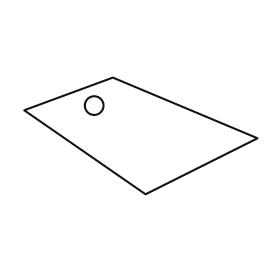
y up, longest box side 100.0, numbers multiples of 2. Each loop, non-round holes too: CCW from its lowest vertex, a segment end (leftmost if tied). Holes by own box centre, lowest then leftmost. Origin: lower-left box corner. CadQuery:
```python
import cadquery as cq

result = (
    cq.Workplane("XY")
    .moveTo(52.0, 0.0)
    .lineTo(100.0, 24.0)
    .lineTo(38.0, 50.0)
    .lineTo(0.0, 36.0)
    .close()
    .moveTo(30.0, 38.0)
    .circle(4.0)
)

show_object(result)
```